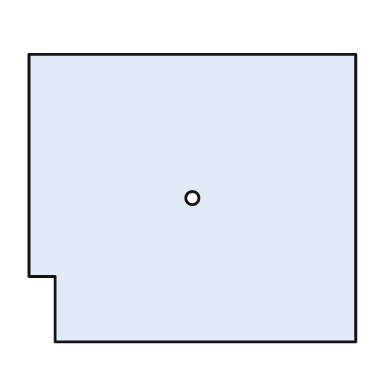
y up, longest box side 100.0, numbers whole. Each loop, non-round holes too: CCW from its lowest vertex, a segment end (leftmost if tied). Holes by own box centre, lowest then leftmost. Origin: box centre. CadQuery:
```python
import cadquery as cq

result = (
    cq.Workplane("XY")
    .moveTo(-42.0, -44.0)
    .lineTo(50.0, -44.0)
    .lineTo(50.0, 44.0)
    .lineTo(-50.0, 44.0)
    .lineTo(-50.0, -24.0)
    .lineTo(-42.0, -24.0)
    .close()
    .moveTo(0.0, 0.0)
    .circle(2.0)
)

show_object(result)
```